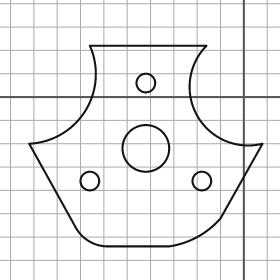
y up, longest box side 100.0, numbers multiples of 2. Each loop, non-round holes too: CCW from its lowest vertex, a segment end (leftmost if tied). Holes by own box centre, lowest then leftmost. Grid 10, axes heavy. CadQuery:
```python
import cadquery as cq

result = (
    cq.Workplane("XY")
    .moveTo(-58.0, -64.0)
    .lineTo(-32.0, -64.0)
    .threePointArc((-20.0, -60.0), (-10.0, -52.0))
    .lineTo(8.0, -20.0)
    .threePointArc((-20.0, -8.0), (-16.0, 22.0))
    .lineTo(-66.0, 22.0)
    .threePointArc((-68.0, -6.0), (-92.0, -20.0))
    .lineTo(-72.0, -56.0)
    .threePointArc((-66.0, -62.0), (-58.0, -64.0))
    .close()
    .moveTo(-66.0, -36.0)
    .circle(4.0)
    .moveTo(-18.0, -36.0)
    .circle(4.0)
    .moveTo(-42.0, -22.0)
    .circle(10.0)
    .moveTo(-42.0, 6.0)
    .circle(4.0)
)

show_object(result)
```